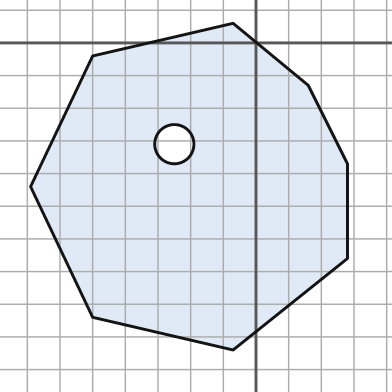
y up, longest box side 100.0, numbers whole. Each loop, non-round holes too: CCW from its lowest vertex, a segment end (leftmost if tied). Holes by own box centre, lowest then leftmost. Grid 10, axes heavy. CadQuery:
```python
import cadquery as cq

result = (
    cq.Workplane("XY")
    .moveTo(-7.0, -94.0)
    .lineTo(28.0, -66.0)
    .lineTo(28.0, -37.0)
    .lineTo(16.0, -13.0)
    .lineTo(-7.0, 6.0)
    .lineTo(-50.0, -4.0)
    .lineTo(-69.0, -44.0)
    .lineTo(-50.0, -84.0)
    .close()
    .moveTo(-25.0, -31.0)
    .circle(6.0)
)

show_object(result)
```